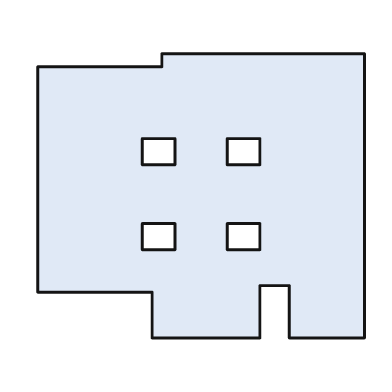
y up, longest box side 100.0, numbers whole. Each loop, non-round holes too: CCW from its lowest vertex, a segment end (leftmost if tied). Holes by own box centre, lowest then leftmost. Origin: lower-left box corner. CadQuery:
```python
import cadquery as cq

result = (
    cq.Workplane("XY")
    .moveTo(35.0, 0.0)
    .lineTo(68.0, 0.0)
    .lineTo(68.0, 16.0)
    .lineTo(77.0, 16.0)
    .lineTo(77.0, 0.0)
    .lineTo(100.0, 0.0)
    .lineTo(100.0, 87.0)
    .lineTo(38.0, 87.0)
    .lineTo(38.0, 83.0)
    .lineTo(0.0, 83.0)
    .lineTo(0.0, 14.0)
    .lineTo(35.0, 14.0)
    .close()
    .moveTo(32.0, 27.0)
    .lineTo(42.0, 27.0)
    .lineTo(42.0, 35.0)
    .lineTo(32.0, 35.0)
    .close()
    .moveTo(58.0, 27.0)
    .lineTo(68.0, 27.0)
    .lineTo(68.0, 35.0)
    .lineTo(58.0, 35.0)
    .close()
    .moveTo(32.0, 53.0)
    .lineTo(42.0, 53.0)
    .lineTo(42.0, 61.0)
    .lineTo(32.0, 61.0)
    .close()
    .moveTo(58.0, 53.0)
    .lineTo(68.0, 53.0)
    .lineTo(68.0, 61.0)
    .lineTo(58.0, 61.0)
    .close()
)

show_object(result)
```